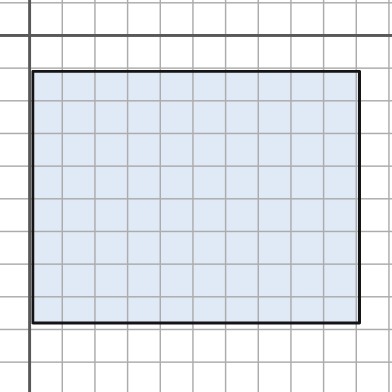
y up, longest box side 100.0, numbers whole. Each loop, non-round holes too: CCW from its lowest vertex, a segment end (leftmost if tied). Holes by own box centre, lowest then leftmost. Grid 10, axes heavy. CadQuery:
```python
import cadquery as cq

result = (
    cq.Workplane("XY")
    .moveTo(1.0, -88.0)
    .lineTo(101.0, -88.0)
    .lineTo(101.0, -11.0)
    .lineTo(1.0, -11.0)
    .close()
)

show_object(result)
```